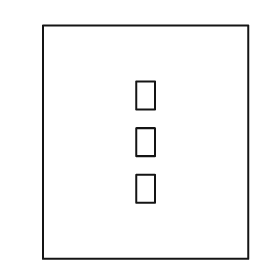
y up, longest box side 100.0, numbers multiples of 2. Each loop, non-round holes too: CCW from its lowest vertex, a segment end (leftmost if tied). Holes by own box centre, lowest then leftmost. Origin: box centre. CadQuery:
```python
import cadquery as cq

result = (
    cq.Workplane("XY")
    .moveTo(-44.0, -50.0)
    .lineTo(44.0, -50.0)
    .lineTo(44.0, 50.0)
    .lineTo(-44.0, 50.0)
    .close()
    .moveTo(-4.0, -26.0)
    .lineTo(4.0, -26.0)
    .lineTo(4.0, -14.0)
    .lineTo(-4.0, -14.0)
    .close()
    .moveTo(-4.0, -6.0)
    .lineTo(4.0, -6.0)
    .lineTo(4.0, 6.0)
    .lineTo(-4.0, 6.0)
    .close()
    .moveTo(-4.0, 14.0)
    .lineTo(4.0, 14.0)
    .lineTo(4.0, 26.0)
    .lineTo(-4.0, 26.0)
    .close()
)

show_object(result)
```